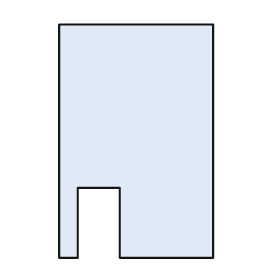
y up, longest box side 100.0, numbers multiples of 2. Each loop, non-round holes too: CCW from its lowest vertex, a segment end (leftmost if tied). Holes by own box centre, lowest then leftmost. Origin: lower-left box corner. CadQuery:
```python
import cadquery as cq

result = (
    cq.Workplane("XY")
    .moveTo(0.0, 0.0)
    .lineTo(8.0, 0.0)
    .lineTo(8.0, 30.0)
    .lineTo(26.0, 30.0)
    .lineTo(26.0, 0.0)
    .lineTo(66.0, 0.0)
    .lineTo(66.0, 100.0)
    .lineTo(0.0, 100.0)
    .close()
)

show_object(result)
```